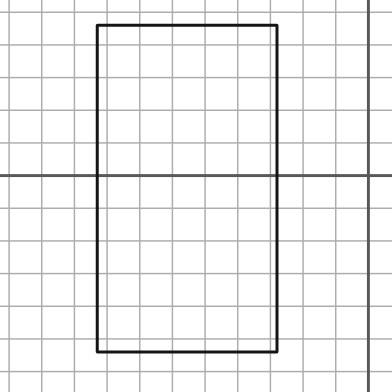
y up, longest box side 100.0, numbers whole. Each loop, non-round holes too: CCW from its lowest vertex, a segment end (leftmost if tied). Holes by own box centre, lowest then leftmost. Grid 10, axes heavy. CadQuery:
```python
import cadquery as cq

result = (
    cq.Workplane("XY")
    .moveTo(-83.0, -54.0)
    .lineTo(-28.0, -54.0)
    .lineTo(-28.0, 46.0)
    .lineTo(-83.0, 46.0)
    .close()
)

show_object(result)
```